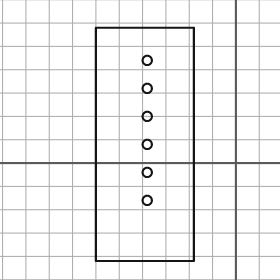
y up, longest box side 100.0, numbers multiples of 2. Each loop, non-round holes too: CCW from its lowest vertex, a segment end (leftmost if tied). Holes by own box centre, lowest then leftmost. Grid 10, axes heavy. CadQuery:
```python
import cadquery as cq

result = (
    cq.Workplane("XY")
    .moveTo(-60.0, -42.0)
    .lineTo(-18.0, -42.0)
    .lineTo(-18.0, 58.0)
    .lineTo(-60.0, 58.0)
    .close()
    .moveTo(-38.0, -16.0)
    .circle(2.0)
    .moveTo(-38.0, -4.0)
    .circle(2.0)
    .moveTo(-38.0, 8.0)
    .circle(2.0)
    .moveTo(-38.0, 20.0)
    .circle(2.0)
    .moveTo(-38.0, 32.0)
    .circle(2.0)
    .moveTo(-38.0, 44.0)
    .circle(2.0)
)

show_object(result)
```